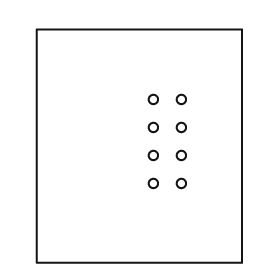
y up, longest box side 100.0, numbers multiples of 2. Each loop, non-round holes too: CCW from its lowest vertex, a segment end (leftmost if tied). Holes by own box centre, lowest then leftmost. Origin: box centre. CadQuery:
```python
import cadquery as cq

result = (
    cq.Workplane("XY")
    .moveTo(-44.0, -50.0)
    .lineTo(44.0, -50.0)
    .lineTo(44.0, 50.0)
    .lineTo(-44.0, 50.0)
    .close()
    .moveTo(6.0, -16.0)
    .circle(2.0)
    .moveTo(18.0, -16.0)
    .circle(2.0)
    .moveTo(6.0, -4.0)
    .circle(2.0)
    .moveTo(18.0, -4.0)
    .circle(2.0)
    .moveTo(6.0, 8.0)
    .circle(2.0)
    .moveTo(18.0, 8.0)
    .circle(2.0)
    .moveTo(6.0, 20.0)
    .circle(2.0)
    .moveTo(18.0, 20.0)
    .circle(2.0)
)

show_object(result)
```